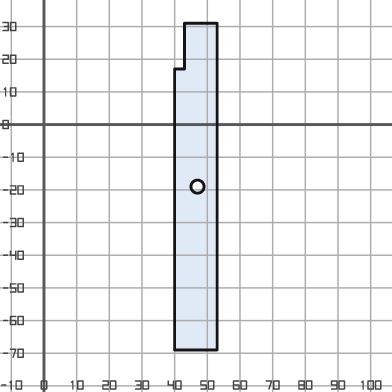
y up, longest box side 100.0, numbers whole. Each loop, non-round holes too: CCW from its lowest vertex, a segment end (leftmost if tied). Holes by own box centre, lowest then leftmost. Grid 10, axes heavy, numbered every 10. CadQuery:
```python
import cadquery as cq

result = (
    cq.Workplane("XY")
    .moveTo(40.0, -69.0)
    .lineTo(53.0, -69.0)
    .lineTo(53.0, 31.0)
    .lineTo(43.0, 31.0)
    .lineTo(43.0, 17.0)
    .lineTo(40.0, 17.0)
    .close()
    .moveTo(47.0, -19.0)
    .circle(2.0)
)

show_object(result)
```